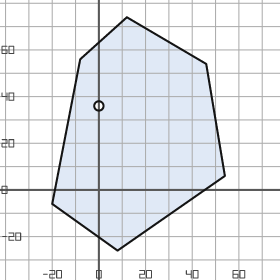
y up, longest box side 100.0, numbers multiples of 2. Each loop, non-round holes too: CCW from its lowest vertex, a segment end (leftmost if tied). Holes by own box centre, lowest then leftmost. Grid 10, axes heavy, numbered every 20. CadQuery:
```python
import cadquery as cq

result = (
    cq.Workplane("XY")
    .moveTo(8.0, -26.0)
    .lineTo(54.0, 6.0)
    .lineTo(46.0, 54.0)
    .lineTo(12.0, 74.0)
    .lineTo(-8.0, 56.0)
    .lineTo(-20.0, -6.0)
    .close()
    .moveTo(0.0, 36.0)
    .circle(2.0)
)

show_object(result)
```